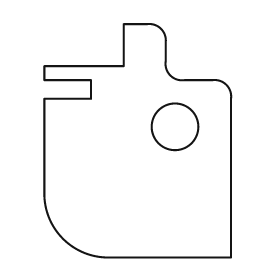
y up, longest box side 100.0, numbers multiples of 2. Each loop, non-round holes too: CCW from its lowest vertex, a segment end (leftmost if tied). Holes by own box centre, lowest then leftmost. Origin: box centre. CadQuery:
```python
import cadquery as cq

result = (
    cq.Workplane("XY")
    .moveTo(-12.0, -50.0)
    .lineTo(40.0, -50.0)
    .lineTo(40.0, 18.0)
    .threePointArc((38.0, 24.0), (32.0, 26.0))
    .lineTo(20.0, 26.0)
    .threePointArc((14.0, 28.0), (12.0, 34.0))
    .lineTo(12.0, 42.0)
    .threePointArc((10.0, 48.0), (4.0, 50.0))
    .lineTo(-6.0, 50.0)
    .lineTo(-6.0, 32.0)
    .lineTo(-40.0, 32.0)
    .lineTo(-40.0, 26.0)
    .lineTo(-20.0, 26.0)
    .lineTo(-20.0, 18.0)
    .lineTo(-40.0, 18.0)
    .lineTo(-40.0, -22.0)
    .threePointArc((-32.0, -42.0), (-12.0, -50.0))
    .close()
    .moveTo(16.0, 6.0)
    .circle(10.0)
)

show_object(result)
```